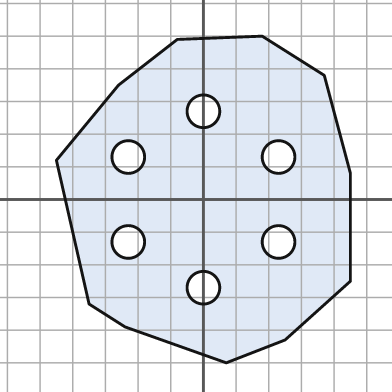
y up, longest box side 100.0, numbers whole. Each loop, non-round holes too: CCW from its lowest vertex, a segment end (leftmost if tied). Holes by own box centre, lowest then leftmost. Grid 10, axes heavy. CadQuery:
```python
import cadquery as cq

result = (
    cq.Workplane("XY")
    .moveTo(7.0, -50.0)
    .lineTo(25.0, -43.0)
    .lineTo(45.0, -25.0)
    .lineTo(45.0, 8.0)
    .lineTo(37.0, 38.0)
    .lineTo(18.0, 50.0)
    .lineTo(-8.0, 49.0)
    .lineTo(-26.0, 35.0)
    .lineTo(-45.0, 12.0)
    .lineTo(-35.0, -32.0)
    .lineTo(-24.0, -39.0)
    .close()
    .moveTo(0.0, -27.0)
    .circle(5.0)
    .moveTo(-23.0, -13.0)
    .circle(5.0)
    .moveTo(23.0, -13.0)
    .circle(5.0)
    .moveTo(-23.0, 13.0)
    .circle(5.0)
    .moveTo(23.0, 13.0)
    .circle(5.0)
    .moveTo(0.0, 27.0)
    .circle(5.0)
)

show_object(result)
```